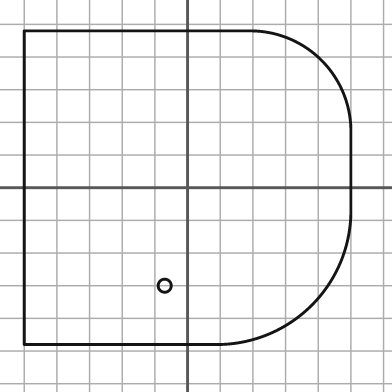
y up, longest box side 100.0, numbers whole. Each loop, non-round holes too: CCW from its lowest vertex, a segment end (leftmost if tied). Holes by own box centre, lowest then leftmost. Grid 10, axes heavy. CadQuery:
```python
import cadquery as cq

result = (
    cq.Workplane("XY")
    .moveTo(-50.0, -48.0)
    .lineTo(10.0, -48.0)
    .threePointArc((38.0, -36.0), (50.0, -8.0))
    .lineTo(50.0, 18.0)
    .threePointArc((41.0, 39.0), (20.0, 48.0))
    .lineTo(-50.0, 48.0)
    .close()
    .moveTo(-7.0, -30.0)
    .circle(2.0)
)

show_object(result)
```